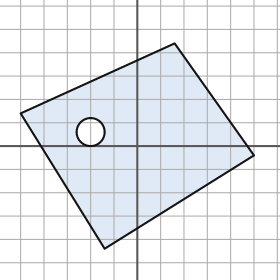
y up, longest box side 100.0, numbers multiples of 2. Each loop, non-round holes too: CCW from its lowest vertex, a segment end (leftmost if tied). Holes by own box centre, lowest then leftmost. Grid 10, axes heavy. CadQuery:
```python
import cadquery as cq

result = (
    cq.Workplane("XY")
    .moveTo(-14.0, -44.0)
    .lineTo(50.0, -4.0)
    .lineTo(16.0, 44.0)
    .lineTo(-50.0, 14.0)
    .close()
    .moveTo(-20.0, 6.0)
    .circle(6.0)
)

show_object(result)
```